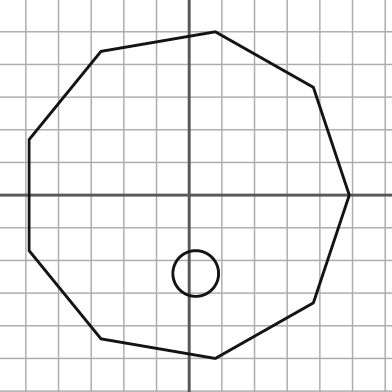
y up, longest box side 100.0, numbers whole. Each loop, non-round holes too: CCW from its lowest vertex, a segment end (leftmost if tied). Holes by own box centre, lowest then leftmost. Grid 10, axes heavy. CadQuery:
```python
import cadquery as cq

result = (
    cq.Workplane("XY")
    .moveTo(8.0, -50.0)
    .lineTo(38.0, -33.0)
    .lineTo(49.0, 0.0)
    .lineTo(38.0, 33.0)
    .lineTo(8.0, 50.0)
    .lineTo(-27.0, 44.0)
    .lineTo(-49.0, 17.0)
    .lineTo(-49.0, -17.0)
    .lineTo(-27.0, -44.0)
    .close()
    .moveTo(2.0, -24.0)
    .circle(7.0)
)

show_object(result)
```